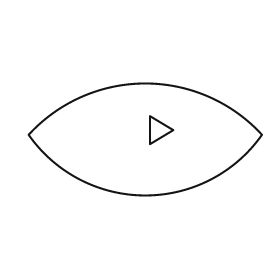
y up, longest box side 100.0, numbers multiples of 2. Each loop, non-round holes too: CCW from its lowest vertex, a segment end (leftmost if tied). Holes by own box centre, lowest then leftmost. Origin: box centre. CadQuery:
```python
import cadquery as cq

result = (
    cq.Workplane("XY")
    .moveTo(-50.0, 2.0)
    .threePointArc((0.0, -24.0), (50.0, 2.0))
    .threePointArc((0.0, 24.0), (-50.0, 2.0))
    .close()
    .moveTo(2.0, -2.0)
    .lineTo(12.0, 4.0)
    .lineTo(2.0, 10.0)
    .close()
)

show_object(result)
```